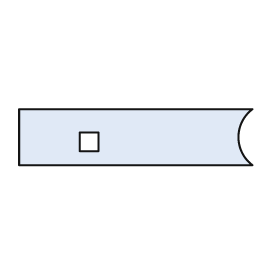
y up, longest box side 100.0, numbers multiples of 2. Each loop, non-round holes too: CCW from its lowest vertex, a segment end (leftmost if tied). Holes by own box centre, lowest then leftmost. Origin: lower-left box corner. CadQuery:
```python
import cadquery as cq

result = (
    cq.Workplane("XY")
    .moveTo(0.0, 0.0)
    .lineTo(100.0, 0.0)
    .threePointArc((94.0, 12.0), (100.0, 24.0))
    .lineTo(0.0, 24.0)
    .close()
    .moveTo(26.0, 6.0)
    .lineTo(34.0, 6.0)
    .lineTo(34.0, 14.0)
    .lineTo(26.0, 14.0)
    .close()
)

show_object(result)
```